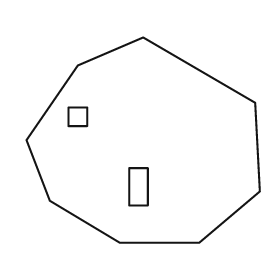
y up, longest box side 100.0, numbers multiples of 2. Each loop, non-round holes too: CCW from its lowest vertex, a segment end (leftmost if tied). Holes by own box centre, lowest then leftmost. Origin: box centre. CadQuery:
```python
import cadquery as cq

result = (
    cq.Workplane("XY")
    .moveTo(-10.0, -44.0)
    .lineTo(24.0, -44.0)
    .lineTo(50.0, -22.0)
    .lineTo(48.0, 16.0)
    .lineTo(0.0, 44.0)
    .lineTo(-28.0, 32.0)
    .lineTo(-50.0, 0.0)
    .lineTo(-40.0, -26.0)
    .close()
    .moveTo(-6.0, -28.0)
    .lineTo(2.0, -28.0)
    .lineTo(2.0, -12.0)
    .lineTo(-6.0, -12.0)
    .close()
    .moveTo(-32.0, 6.0)
    .lineTo(-24.0, 6.0)
    .lineTo(-24.0, 14.0)
    .lineTo(-32.0, 14.0)
    .close()
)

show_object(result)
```